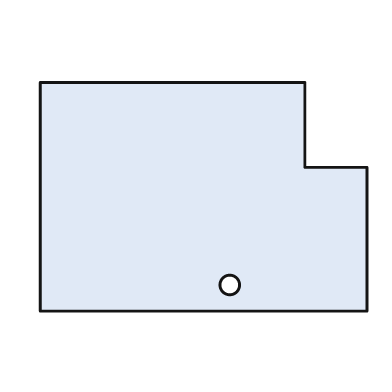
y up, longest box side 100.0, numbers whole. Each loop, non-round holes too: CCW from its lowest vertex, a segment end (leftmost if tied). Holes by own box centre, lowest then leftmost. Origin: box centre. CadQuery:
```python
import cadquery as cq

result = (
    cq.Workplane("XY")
    .moveTo(-50.0, -35.0)
    .lineTo(50.0, -35.0)
    .lineTo(50.0, 9.0)
    .lineTo(31.0, 9.0)
    .lineTo(31.0, 35.0)
    .lineTo(-50.0, 35.0)
    .close()
    .moveTo(8.0, -27.0)
    .circle(3.0)
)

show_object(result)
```